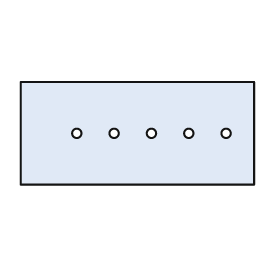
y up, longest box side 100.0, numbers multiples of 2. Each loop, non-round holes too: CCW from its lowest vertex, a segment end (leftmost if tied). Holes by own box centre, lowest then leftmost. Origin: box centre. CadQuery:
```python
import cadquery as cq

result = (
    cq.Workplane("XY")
    .moveTo(-50.0, -22.0)
    .lineTo(50.0, -22.0)
    .lineTo(50.0, 22.0)
    .lineTo(-50.0, 22.0)
    .close()
    .moveTo(-26.0, 0.0)
    .circle(2.0)
    .moveTo(-10.0, 0.0)
    .circle(2.0)
    .moveTo(6.0, 0.0)
    .circle(2.0)
    .moveTo(22.0, 0.0)
    .circle(2.0)
    .moveTo(38.0, 0.0)
    .circle(2.0)
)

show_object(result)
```